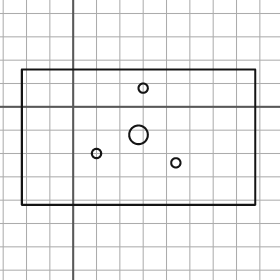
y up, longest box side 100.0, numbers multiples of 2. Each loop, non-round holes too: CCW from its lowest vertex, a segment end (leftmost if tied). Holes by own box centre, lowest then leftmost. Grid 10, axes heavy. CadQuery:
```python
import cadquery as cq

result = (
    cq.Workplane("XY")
    .moveTo(-22.0, -42.0)
    .lineTo(78.0, -42.0)
    .lineTo(78.0, 16.0)
    .lineTo(-22.0, 16.0)
    .close()
    .moveTo(44.0, -24.0)
    .circle(2.0)
    .moveTo(10.0, -20.0)
    .circle(2.0)
    .moveTo(28.0, -12.0)
    .circle(4.0)
    .moveTo(30.0, 8.0)
    .circle(2.0)
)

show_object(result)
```